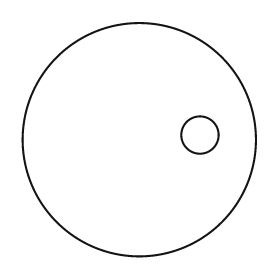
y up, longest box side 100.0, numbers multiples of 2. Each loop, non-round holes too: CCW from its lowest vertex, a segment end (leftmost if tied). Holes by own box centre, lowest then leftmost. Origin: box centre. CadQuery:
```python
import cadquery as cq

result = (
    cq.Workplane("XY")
    .moveTo(0.0, 0.0)
    .circle(50.0)
    .moveTo(26.0, 2.0)
    .circle(8.0)
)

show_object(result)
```